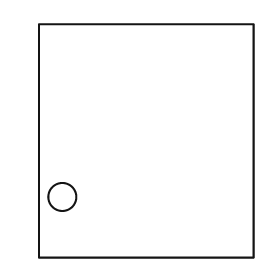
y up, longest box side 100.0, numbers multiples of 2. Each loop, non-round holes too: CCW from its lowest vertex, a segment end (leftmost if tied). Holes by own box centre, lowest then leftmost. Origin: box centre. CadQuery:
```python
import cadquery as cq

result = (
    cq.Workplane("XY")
    .moveTo(-46.0, -50.0)
    .lineTo(46.0, -50.0)
    .lineTo(46.0, 50.0)
    .lineTo(-46.0, 50.0)
    .close()
    .moveTo(-36.0, -24.0)
    .circle(6.0)
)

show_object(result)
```